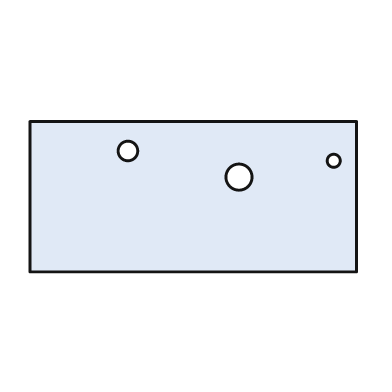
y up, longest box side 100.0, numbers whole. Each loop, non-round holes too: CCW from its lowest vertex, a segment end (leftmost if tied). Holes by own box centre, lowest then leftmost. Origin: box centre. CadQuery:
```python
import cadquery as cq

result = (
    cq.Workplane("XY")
    .moveTo(-50.0, -23.0)
    .lineTo(50.0, -23.0)
    .lineTo(50.0, 23.0)
    .lineTo(-50.0, 23.0)
    .close()
    .moveTo(14.0, 6.0)
    .circle(4.0)
    .moveTo(43.0, 11.0)
    .circle(2.0)
    .moveTo(-20.0, 14.0)
    .circle(3.0)
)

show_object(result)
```